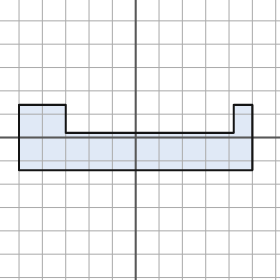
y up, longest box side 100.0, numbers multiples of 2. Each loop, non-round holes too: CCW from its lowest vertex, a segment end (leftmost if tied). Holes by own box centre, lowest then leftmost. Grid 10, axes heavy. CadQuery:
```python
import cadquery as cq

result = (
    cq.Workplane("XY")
    .moveTo(-50.0, -14.0)
    .lineTo(50.0, -14.0)
    .lineTo(50.0, 14.0)
    .lineTo(42.0, 14.0)
    .lineTo(42.0, 2.0)
    .lineTo(-30.0, 2.0)
    .lineTo(-30.0, 14.0)
    .lineTo(-50.0, 14.0)
    .close()
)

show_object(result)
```